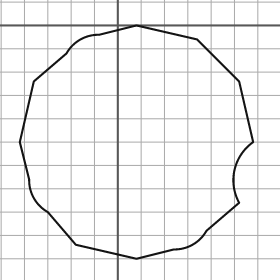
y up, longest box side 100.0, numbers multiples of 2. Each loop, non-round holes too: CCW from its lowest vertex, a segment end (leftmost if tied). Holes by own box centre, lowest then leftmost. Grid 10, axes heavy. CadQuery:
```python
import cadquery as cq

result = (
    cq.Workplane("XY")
    .moveTo(8.0, -100.0)
    .lineTo(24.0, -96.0)
    .threePointArc((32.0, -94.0), (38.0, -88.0))
    .lineTo(52.0, -76.0)
    .threePointArc((50.0, -62.0), (58.0, -50.0))
    .lineTo(52.0, -24.0)
    .lineTo(34.0, -6.0)
    .lineTo(8.0, 0.0)
    .lineTo(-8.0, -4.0)
    .threePointArc((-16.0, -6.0), (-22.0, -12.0))
    .lineTo(-36.0, -24.0)
    .lineTo(-42.0, -50.0)
    .lineTo(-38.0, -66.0)
    .threePointArc((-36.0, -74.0), (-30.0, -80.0))
    .lineTo(-18.0, -94.0)
    .close()
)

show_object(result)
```